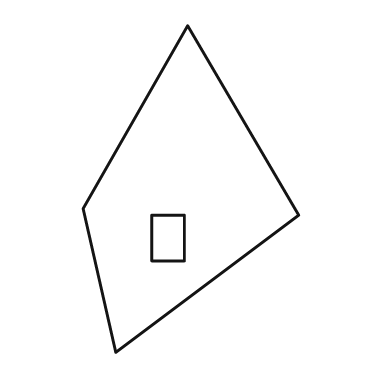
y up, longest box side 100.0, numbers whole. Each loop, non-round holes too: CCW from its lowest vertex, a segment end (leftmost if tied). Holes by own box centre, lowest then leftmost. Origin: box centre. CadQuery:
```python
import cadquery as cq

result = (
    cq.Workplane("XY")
    .moveTo(-23.0, -50.0)
    .lineTo(33.0, -8.0)
    .lineTo(-1.0, 50.0)
    .lineTo(-33.0, -6.0)
    .close()
    .moveTo(-12.0, -22.0)
    .lineTo(-2.0, -22.0)
    .lineTo(-2.0, -8.0)
    .lineTo(-12.0, -8.0)
    .close()
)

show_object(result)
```